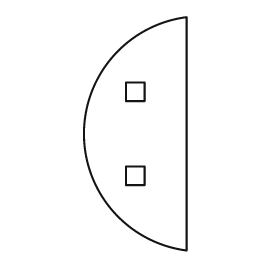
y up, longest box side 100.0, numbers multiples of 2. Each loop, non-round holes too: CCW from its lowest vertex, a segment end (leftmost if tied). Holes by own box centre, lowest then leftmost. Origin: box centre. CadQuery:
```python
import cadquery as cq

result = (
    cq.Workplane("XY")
    .moveTo(22.0, -50.0)
    .lineTo(22.0, 50.0)
    .threePointArc((-22.0, 0.0), (22.0, -50.0))
    .close()
    .moveTo(-4.0, -22.0)
    .lineTo(4.0, -22.0)
    .lineTo(4.0, -14.0)
    .lineTo(-4.0, -14.0)
    .close()
    .moveTo(-4.0, 14.0)
    .lineTo(4.0, 14.0)
    .lineTo(4.0, 22.0)
    .lineTo(-4.0, 22.0)
    .close()
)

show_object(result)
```